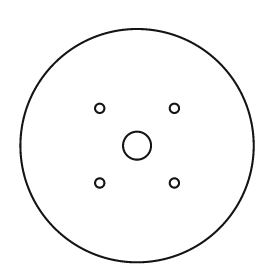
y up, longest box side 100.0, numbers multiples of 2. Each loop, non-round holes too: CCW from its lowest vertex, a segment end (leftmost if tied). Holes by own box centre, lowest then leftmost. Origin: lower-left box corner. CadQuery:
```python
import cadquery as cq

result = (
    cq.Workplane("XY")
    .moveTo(50.0, 50.0)
    .circle(50.0)
    .moveTo(34.0, 34.0)
    .circle(2.0)
    .moveTo(66.0, 34.0)
    .circle(2.0)
    .moveTo(50.0, 50.0)
    .circle(6.0)
    .moveTo(34.0, 66.0)
    .circle(2.0)
    .moveTo(66.0, 66.0)
    .circle(2.0)
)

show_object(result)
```